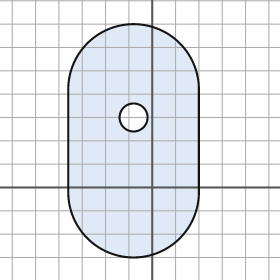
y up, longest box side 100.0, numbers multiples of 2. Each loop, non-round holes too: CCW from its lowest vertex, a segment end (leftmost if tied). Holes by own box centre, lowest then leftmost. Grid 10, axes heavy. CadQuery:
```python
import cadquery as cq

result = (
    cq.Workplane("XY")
    .moveTo(-36.0, -2.0)
    .threePointArc((-8.0, -30.0), (20.0, -2.0))
    .lineTo(20.0, 42.0)
    .threePointArc((-8.0, 70.0), (-36.0, 42.0))
    .close()
    .moveTo(-8.0, 30.0)
    .circle(6.0)
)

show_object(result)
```